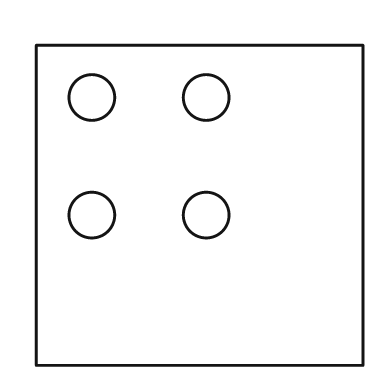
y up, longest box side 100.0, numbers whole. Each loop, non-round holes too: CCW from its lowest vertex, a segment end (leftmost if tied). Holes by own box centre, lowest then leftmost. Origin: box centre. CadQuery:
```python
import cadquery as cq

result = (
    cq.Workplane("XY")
    .moveTo(-50.0, -49.0)
    .lineTo(50.0, -49.0)
    .lineTo(50.0, 49.0)
    .lineTo(-50.0, 49.0)
    .close()
    .moveTo(-33.0, -3.0)
    .circle(7.0)
    .moveTo(2.0, -3.0)
    .circle(7.0)
    .moveTo(-33.0, 33.0)
    .circle(7.0)
    .moveTo(2.0, 33.0)
    .circle(7.0)
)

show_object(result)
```